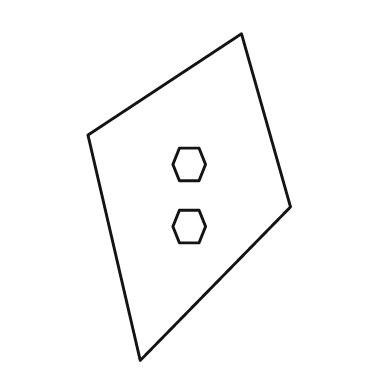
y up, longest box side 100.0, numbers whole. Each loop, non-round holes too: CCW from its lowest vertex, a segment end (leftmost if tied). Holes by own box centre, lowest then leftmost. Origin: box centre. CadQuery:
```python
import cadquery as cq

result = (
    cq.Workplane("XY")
    .moveTo(-15.0, -50.0)
    .lineTo(31.0, -3.0)
    .lineTo(16.0, 50.0)
    .lineTo(-31.0, 19.0)
    .close()
    .moveTo(-3.0, -14.0)
    .lineTo(3.0, -14.0)
    .lineTo(5.0, -9.0)
    .lineTo(3.0, -4.0)
    .lineTo(-3.0, -4.0)
    .lineTo(-5.0, -9.0)
    .close()
    .moveTo(-3.0, 5.0)
    .lineTo(3.0, 5.0)
    .lineTo(5.0, 10.0)
    .lineTo(3.0, 15.0)
    .lineTo(-3.0, 15.0)
    .lineTo(-5.0, 10.0)
    .close()
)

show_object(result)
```